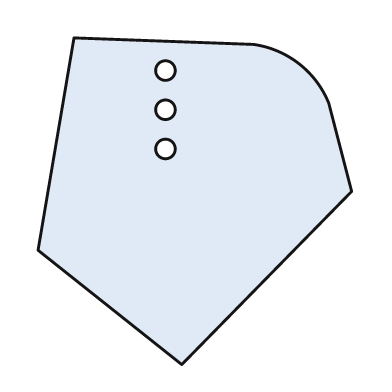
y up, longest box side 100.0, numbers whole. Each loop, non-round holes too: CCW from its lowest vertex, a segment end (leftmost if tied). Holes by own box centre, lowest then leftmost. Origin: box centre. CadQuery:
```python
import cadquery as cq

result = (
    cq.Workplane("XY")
    .moveTo(-4.0, -50.0)
    .lineTo(48.0, 3.0)
    .lineTo(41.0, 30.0)
    .threePointArc((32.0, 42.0), (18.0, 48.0))
    .lineTo(-37.0, 50.0)
    .lineTo(-48.0, -15.0)
    .close()
    .moveTo(-9.0, 16.0)
    .circle(3.0)
    .moveTo(-9.0, 28.0)
    .circle(3.0)
    .moveTo(-9.0, 40.0)
    .circle(3.0)
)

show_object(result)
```